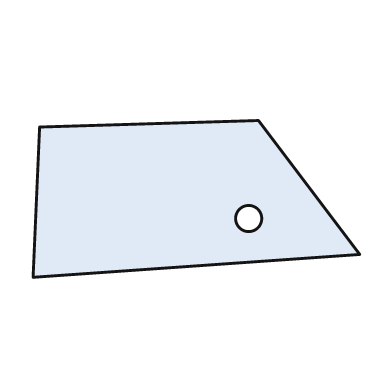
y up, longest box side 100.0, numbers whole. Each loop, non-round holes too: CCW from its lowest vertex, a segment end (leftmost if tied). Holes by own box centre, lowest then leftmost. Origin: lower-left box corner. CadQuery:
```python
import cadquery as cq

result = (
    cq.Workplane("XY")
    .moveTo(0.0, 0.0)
    .lineTo(100.0, 7.0)
    .lineTo(69.0, 48.0)
    .lineTo(2.0, 46.0)
    .close()
    .moveTo(66.0, 18.0)
    .circle(4.0)
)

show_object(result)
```